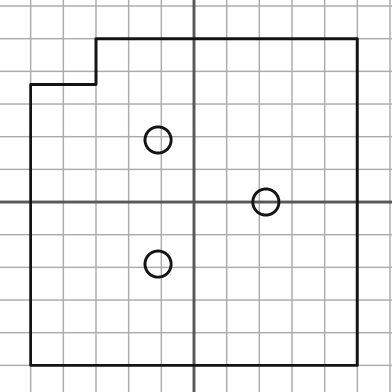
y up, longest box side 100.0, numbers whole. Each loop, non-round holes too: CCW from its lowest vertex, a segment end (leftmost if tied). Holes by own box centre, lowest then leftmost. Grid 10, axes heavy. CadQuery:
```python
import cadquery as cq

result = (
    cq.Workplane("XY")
    .moveTo(-50.0, -50.0)
    .lineTo(50.0, -50.0)
    .lineTo(50.0, 50.0)
    .lineTo(-30.0, 50.0)
    .lineTo(-30.0, 36.0)
    .lineTo(-50.0, 36.0)
    .close()
    .moveTo(-11.0, -19.0)
    .circle(4.0)
    .moveTo(22.0, 0.0)
    .circle(4.0)
    .moveTo(-11.0, 19.0)
    .circle(4.0)
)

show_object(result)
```